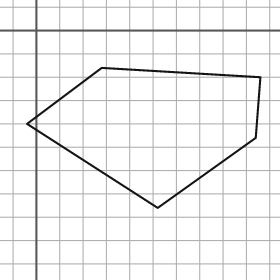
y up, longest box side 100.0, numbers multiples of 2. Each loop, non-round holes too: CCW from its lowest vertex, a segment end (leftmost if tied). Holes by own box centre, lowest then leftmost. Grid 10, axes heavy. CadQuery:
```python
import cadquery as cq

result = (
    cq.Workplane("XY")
    .moveTo(52.0, -76.0)
    .lineTo(94.0, -46.0)
    .lineTo(96.0, -20.0)
    .lineTo(28.0, -16.0)
    .lineTo(-4.0, -40.0)
    .close()
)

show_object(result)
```